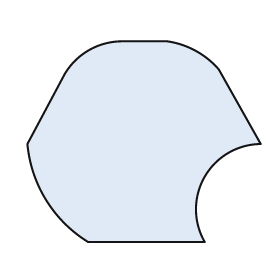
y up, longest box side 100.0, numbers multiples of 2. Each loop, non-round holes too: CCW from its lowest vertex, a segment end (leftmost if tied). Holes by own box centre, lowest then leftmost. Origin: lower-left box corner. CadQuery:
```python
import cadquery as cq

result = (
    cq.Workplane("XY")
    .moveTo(26.0, 0.0)
    .lineTo(76.0, 0.0)
    .threePointArc((76.0, 28.0), (100.0, 42.0))
    .lineTo(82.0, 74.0)
    .threePointArc((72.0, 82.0), (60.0, 86.0))
    .lineTo(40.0, 86.0)
    .threePointArc((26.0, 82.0), (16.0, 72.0))
    .lineTo(0.0, 42.0)
    .threePointArc((8.0, 18.0), (26.0, 0.0))
    .close()
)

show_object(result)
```